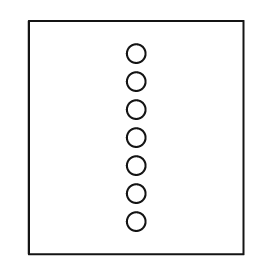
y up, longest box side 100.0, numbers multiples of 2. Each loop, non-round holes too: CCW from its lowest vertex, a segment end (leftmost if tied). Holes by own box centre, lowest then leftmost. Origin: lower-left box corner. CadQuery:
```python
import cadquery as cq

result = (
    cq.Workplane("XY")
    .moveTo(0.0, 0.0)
    .lineTo(92.0, 0.0)
    .lineTo(92.0, 100.0)
    .lineTo(0.0, 100.0)
    .close()
    .moveTo(46.0, 14.0)
    .circle(4.0)
    .moveTo(46.0, 26.0)
    .circle(4.0)
    .moveTo(46.0, 38.0)
    .circle(4.0)
    .moveTo(46.0, 50.0)
    .circle(4.0)
    .moveTo(46.0, 62.0)
    .circle(4.0)
    .moveTo(46.0, 74.0)
    .circle(4.0)
    .moveTo(46.0, 86.0)
    .circle(4.0)
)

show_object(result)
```